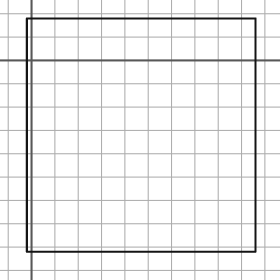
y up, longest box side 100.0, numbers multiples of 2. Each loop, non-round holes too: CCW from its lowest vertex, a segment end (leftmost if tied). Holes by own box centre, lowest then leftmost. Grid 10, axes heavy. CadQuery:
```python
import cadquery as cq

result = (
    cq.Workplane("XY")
    .moveTo(-2.0, -82.0)
    .lineTo(96.0, -82.0)
    .lineTo(96.0, 18.0)
    .lineTo(-2.0, 18.0)
    .close()
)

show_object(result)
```